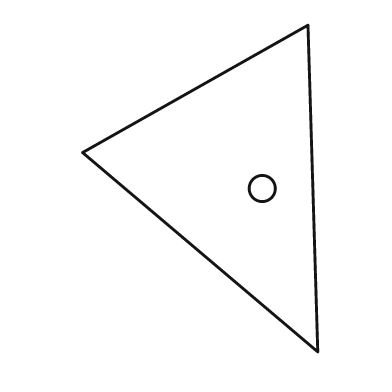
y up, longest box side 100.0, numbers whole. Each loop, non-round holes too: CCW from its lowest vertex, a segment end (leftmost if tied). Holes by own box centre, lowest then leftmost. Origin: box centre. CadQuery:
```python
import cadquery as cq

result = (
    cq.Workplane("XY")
    .moveTo(36.0, -50.0)
    .lineTo(33.0, 50.0)
    .lineTo(-36.0, 11.0)
    .close()
    .moveTo(19.0, 0.0)
    .circle(4.0)
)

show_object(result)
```